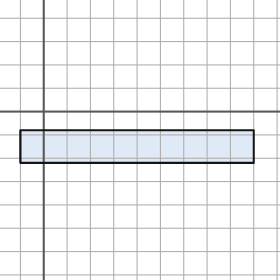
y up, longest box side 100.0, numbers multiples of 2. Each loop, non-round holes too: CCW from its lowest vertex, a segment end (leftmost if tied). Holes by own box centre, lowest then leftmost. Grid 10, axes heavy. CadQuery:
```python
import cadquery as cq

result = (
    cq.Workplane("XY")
    .moveTo(-10.0, -22.0)
    .lineTo(90.0, -22.0)
    .lineTo(90.0, -8.0)
    .lineTo(-10.0, -8.0)
    .close()
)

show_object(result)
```